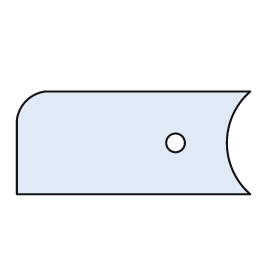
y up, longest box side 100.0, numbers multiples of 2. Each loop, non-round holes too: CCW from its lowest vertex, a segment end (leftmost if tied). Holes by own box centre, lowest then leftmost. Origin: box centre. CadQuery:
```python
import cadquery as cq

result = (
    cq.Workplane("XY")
    .moveTo(-50.0, -22.0)
    .lineTo(50.0, -22.0)
    .threePointArc((40.0, 0.0), (50.0, 22.0))
    .lineTo(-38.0, 22.0)
    .threePointArc((-46.0, 18.0), (-50.0, 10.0))
    .close()
    .moveTo(18.0, 0.0)
    .circle(4.0)
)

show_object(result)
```